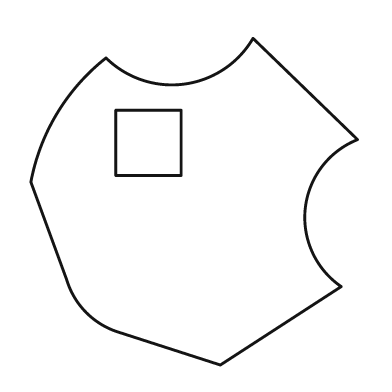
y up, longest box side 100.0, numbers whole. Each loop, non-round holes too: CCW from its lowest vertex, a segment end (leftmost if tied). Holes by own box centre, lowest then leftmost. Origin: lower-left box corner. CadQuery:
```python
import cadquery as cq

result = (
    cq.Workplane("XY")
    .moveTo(58.0, 0.0)
    .lineTo(95.0, 24.0)
    .threePointArc((84.0, 48.0), (100.0, 69.0))
    .lineTo(68.0, 100.0)
    .threePointArc((47.0, 86.0), (23.0, 94.0))
    .threePointArc((8.0, 77.0), (0.0, 56.0))
    .lineTo(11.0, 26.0)
    .threePointArc((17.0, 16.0), (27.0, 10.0))
    .close()
    .moveTo(26.0, 58.0)
    .lineTo(46.0, 58.0)
    .lineTo(46.0, 78.0)
    .lineTo(26.0, 78.0)
    .close()
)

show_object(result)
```